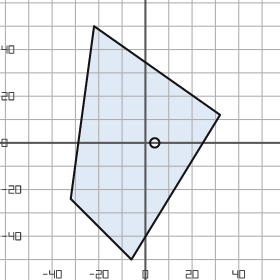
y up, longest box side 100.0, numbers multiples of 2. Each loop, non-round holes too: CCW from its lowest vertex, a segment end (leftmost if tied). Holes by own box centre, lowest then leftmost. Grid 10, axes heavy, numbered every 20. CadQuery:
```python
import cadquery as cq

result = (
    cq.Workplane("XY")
    .moveTo(-6.0, -50.0)
    .lineTo(32.0, 12.0)
    .lineTo(-22.0, 50.0)
    .lineTo(-32.0, -24.0)
    .close()
    .moveTo(4.0, 0.0)
    .circle(2.0)
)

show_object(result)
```